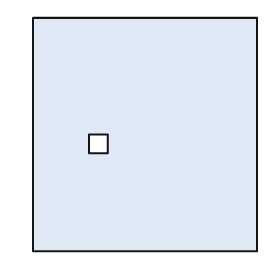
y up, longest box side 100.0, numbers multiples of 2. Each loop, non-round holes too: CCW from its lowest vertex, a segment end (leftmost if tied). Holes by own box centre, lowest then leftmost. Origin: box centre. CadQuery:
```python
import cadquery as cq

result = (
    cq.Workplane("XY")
    .moveTo(-48.0, -50.0)
    .lineTo(48.0, -50.0)
    .lineTo(48.0, 50.0)
    .lineTo(-48.0, 50.0)
    .close()
    .moveTo(-24.0, -8.0)
    .lineTo(-16.0, -8.0)
    .lineTo(-16.0, 0.0)
    .lineTo(-24.0, 0.0)
    .close()
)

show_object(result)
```